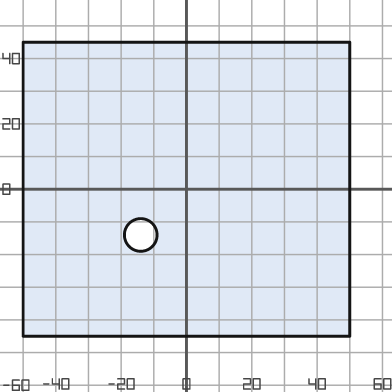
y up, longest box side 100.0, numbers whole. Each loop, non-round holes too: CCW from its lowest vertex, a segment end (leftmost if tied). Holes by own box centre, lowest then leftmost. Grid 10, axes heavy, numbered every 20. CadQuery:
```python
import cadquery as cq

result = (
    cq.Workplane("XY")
    .moveTo(-50.0, -45.0)
    .lineTo(50.0, -45.0)
    .lineTo(50.0, 45.0)
    .lineTo(-50.0, 45.0)
    .close()
    .moveTo(-14.0, -14.0)
    .circle(5.0)
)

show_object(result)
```